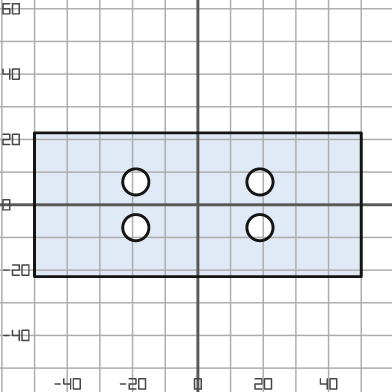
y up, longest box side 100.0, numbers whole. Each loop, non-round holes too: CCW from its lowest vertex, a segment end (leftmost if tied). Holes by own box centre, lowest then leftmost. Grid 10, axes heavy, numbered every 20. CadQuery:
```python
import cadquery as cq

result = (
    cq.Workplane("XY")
    .moveTo(-50.0, -22.0)
    .lineTo(50.0, -22.0)
    .lineTo(50.0, 22.0)
    .lineTo(-50.0, 22.0)
    .close()
    .moveTo(-19.0, -7.0)
    .circle(4.0)
    .moveTo(19.0, -7.0)
    .circle(4.0)
    .moveTo(-19.0, 7.0)
    .circle(4.0)
    .moveTo(19.0, 7.0)
    .circle(4.0)
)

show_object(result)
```